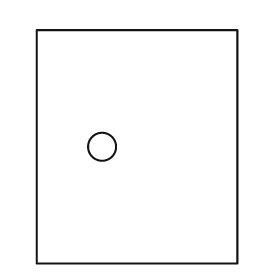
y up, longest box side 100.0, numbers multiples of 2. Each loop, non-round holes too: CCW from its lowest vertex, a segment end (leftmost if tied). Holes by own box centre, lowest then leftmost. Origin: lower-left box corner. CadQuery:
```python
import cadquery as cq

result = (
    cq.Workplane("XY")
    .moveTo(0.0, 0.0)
    .lineTo(86.0, 0.0)
    .lineTo(86.0, 100.0)
    .lineTo(0.0, 100.0)
    .close()
    .moveTo(28.0, 50.0)
    .circle(6.0)
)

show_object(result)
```